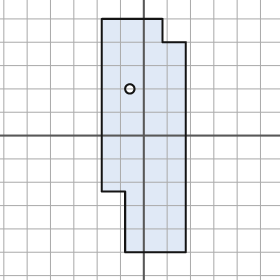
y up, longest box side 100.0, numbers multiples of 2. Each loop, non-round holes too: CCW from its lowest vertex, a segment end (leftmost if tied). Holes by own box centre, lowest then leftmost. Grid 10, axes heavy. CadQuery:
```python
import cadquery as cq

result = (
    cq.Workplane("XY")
    .moveTo(-8.0, -50.0)
    .lineTo(18.0, -50.0)
    .lineTo(18.0, 40.0)
    .lineTo(8.0, 40.0)
    .lineTo(8.0, 50.0)
    .lineTo(-18.0, 50.0)
    .lineTo(-18.0, -24.0)
    .lineTo(-8.0, -24.0)
    .close()
    .moveTo(-6.0, 20.0)
    .circle(2.0)
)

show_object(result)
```